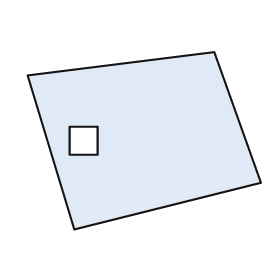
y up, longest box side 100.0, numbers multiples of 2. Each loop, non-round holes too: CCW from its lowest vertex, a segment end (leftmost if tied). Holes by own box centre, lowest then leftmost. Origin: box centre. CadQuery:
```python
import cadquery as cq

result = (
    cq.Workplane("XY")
    .moveTo(-30.0, -38.0)
    .lineTo(50.0, -18.0)
    .lineTo(30.0, 38.0)
    .lineTo(-50.0, 28.0)
    .close()
    .moveTo(-32.0, -6.0)
    .lineTo(-20.0, -6.0)
    .lineTo(-20.0, 6.0)
    .lineTo(-32.0, 6.0)
    .close()
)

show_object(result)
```